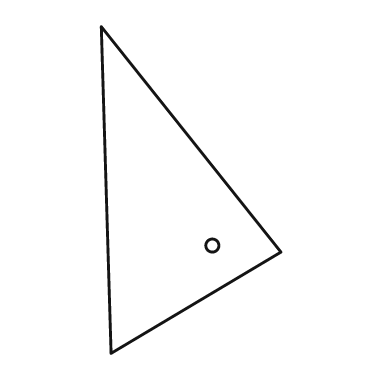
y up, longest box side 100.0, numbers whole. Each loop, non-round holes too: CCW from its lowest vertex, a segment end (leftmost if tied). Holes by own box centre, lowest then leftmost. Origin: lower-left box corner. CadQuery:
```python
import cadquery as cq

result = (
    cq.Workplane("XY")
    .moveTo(3.0, 0.0)
    .lineTo(55.0, 31.0)
    .lineTo(0.0, 100.0)
    .close()
    .moveTo(34.0, 33.0)
    .circle(2.0)
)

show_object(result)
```